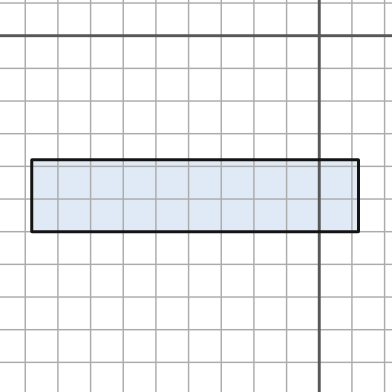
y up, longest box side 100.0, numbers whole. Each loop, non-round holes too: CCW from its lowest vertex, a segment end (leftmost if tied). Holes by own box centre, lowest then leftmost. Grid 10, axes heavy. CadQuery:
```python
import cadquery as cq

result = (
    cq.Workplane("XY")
    .moveTo(-88.0, -60.0)
    .lineTo(12.0, -60.0)
    .lineTo(12.0, -38.0)
    .lineTo(-88.0, -38.0)
    .close()
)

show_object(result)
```